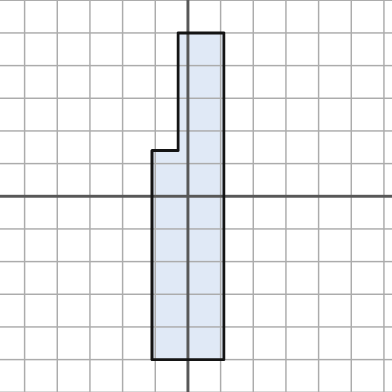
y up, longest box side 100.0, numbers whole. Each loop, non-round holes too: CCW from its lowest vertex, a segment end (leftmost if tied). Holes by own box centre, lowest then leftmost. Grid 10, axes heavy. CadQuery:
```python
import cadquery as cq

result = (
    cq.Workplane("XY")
    .moveTo(-11.0, -50.0)
    .lineTo(11.0, -50.0)
    .lineTo(11.0, 50.0)
    .lineTo(-3.0, 50.0)
    .lineTo(-3.0, 14.0)
    .lineTo(-11.0, 14.0)
    .close()
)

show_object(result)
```